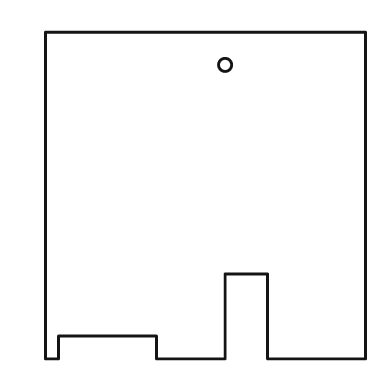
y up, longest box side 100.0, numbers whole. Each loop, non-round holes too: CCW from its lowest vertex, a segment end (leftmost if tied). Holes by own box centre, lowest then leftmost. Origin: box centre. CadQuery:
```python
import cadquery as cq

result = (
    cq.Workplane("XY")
    .moveTo(-49.0, -50.0)
    .lineTo(-45.0, -50.0)
    .lineTo(-45.0, -43.0)
    .lineTo(-15.0, -43.0)
    .lineTo(-15.0, -50.0)
    .lineTo(6.0, -50.0)
    .lineTo(6.0, -24.0)
    .lineTo(19.0, -24.0)
    .lineTo(19.0, -50.0)
    .lineTo(49.0, -50.0)
    .lineTo(49.0, 50.0)
    .lineTo(-49.0, 50.0)
    .close()
    .moveTo(6.0, 40.0)
    .circle(2.0)
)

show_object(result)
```